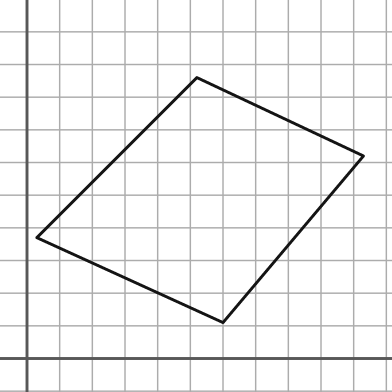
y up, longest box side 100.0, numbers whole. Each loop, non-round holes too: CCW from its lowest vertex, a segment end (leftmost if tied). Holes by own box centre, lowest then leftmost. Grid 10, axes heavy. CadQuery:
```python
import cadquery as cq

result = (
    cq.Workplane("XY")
    .moveTo(60.0, 11.0)
    .lineTo(103.0, 62.0)
    .lineTo(52.0, 86.0)
    .lineTo(3.0, 37.0)
    .close()
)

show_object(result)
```